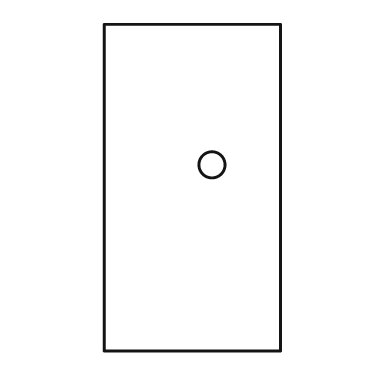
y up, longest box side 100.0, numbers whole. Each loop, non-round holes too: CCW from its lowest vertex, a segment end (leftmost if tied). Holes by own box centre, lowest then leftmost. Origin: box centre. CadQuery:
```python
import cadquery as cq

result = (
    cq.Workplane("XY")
    .moveTo(-27.0, -50.0)
    .lineTo(27.0, -50.0)
    .lineTo(27.0, 50.0)
    .lineTo(-27.0, 50.0)
    .close()
    .moveTo(6.0, 7.0)
    .circle(4.0)
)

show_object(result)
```